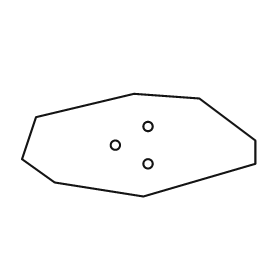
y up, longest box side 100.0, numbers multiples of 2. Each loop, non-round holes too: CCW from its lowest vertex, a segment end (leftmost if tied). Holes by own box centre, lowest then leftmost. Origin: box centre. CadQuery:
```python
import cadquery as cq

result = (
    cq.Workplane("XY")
    .moveTo(2.0, -22.0)
    .lineTo(50.0, -8.0)
    .lineTo(50.0, 2.0)
    .lineTo(26.0, 20.0)
    .lineTo(-2.0, 22.0)
    .lineTo(-44.0, 12.0)
    .lineTo(-50.0, -6.0)
    .lineTo(-36.0, -16.0)
    .close()
    .moveTo(4.0, -8.0)
    .circle(2.0)
    .moveTo(-10.0, 0.0)
    .circle(2.0)
    .moveTo(4.0, 8.0)
    .circle(2.0)
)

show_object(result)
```